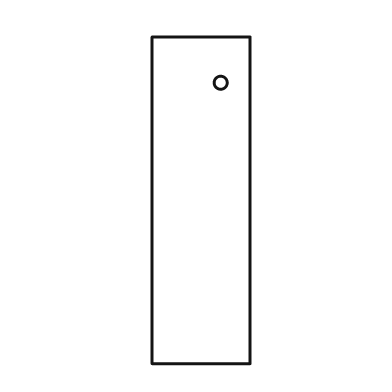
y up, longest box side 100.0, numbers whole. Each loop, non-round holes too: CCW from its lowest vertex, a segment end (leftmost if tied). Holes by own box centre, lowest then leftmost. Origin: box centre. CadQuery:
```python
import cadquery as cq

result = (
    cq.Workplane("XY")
    .moveTo(-15.0, -50.0)
    .lineTo(15.0, -50.0)
    .lineTo(15.0, 50.0)
    .lineTo(-15.0, 50.0)
    .close()
    .moveTo(6.0, 36.0)
    .circle(2.0)
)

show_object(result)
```